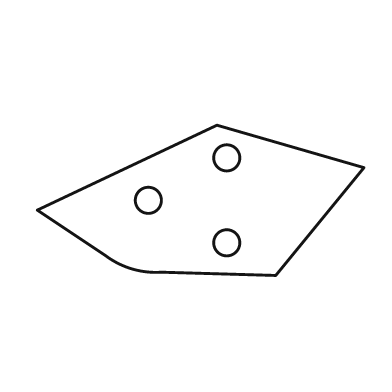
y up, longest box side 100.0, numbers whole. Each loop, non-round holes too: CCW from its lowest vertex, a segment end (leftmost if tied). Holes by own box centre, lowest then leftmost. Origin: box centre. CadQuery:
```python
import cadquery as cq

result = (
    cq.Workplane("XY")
    .moveTo(23.0, -23.0)
    .lineTo(50.0, 10.0)
    .lineTo(5.0, 23.0)
    .lineTo(-50.0, -3.0)
    .lineTo(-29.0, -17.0)
    .threePointArc((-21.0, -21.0), (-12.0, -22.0))
    .close()
    .moveTo(8.0, -13.0)
    .circle(4.0)
    .moveTo(-16.0, 0.0)
    .circle(4.0)
    .moveTo(8.0, 13.0)
    .circle(4.0)
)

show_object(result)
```